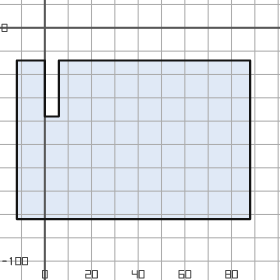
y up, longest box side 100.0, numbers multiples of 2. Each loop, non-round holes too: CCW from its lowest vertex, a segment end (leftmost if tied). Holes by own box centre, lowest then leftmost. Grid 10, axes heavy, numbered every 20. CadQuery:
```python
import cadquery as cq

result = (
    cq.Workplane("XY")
    .moveTo(-12.0, -82.0)
    .lineTo(88.0, -82.0)
    .lineTo(88.0, -14.0)
    .lineTo(6.0, -14.0)
    .lineTo(6.0, -38.0)
    .lineTo(0.0, -38.0)
    .lineTo(0.0, -14.0)
    .lineTo(-12.0, -14.0)
    .close()
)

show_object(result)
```